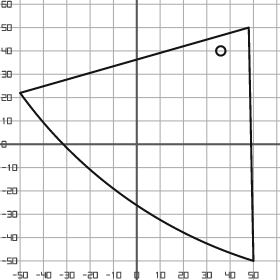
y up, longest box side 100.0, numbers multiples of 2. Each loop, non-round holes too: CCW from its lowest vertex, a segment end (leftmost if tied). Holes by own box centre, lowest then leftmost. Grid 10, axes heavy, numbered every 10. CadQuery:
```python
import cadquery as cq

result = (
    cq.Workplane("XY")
    .moveTo(50.0, -50.0)
    .lineTo(48.0, 50.0)
    .lineTo(-50.0, 22.0)
    .threePointArc((-6.0, -22.0), (50.0, -50.0))
    .close()
    .moveTo(36.0, 40.0)
    .circle(2.0)
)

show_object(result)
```